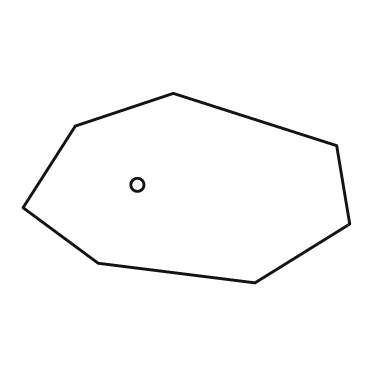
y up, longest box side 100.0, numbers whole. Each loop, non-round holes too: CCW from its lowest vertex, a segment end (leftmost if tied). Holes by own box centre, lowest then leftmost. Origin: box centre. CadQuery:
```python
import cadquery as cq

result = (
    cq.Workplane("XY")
    .moveTo(21.0, -29.0)
    .lineTo(50.0, -11.0)
    .lineTo(46.0, 13.0)
    .lineTo(-4.0, 29.0)
    .lineTo(-34.0, 19.0)
    .lineTo(-50.0, -6.0)
    .lineTo(-27.0, -23.0)
    .close()
    .moveTo(-15.0, 1.0)
    .circle(2.0)
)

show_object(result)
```